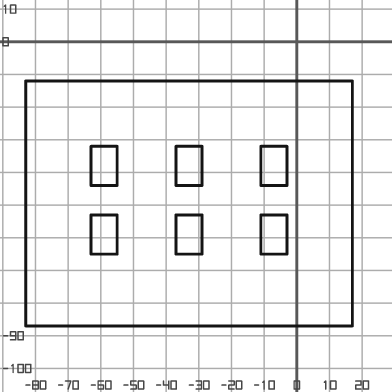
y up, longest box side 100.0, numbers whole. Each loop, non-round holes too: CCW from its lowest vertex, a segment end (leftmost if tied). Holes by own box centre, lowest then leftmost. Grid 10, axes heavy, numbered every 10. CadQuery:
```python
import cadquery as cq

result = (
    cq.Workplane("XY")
    .moveTo(-83.0, -87.0)
    .lineTo(17.0, -87.0)
    .lineTo(17.0, -12.0)
    .lineTo(-83.0, -12.0)
    .close()
    .moveTo(-63.0, -65.0)
    .lineTo(-55.0, -65.0)
    .lineTo(-55.0, -53.0)
    .lineTo(-63.0, -53.0)
    .close()
    .moveTo(-37.0, -65.0)
    .lineTo(-29.0, -65.0)
    .lineTo(-29.0, -53.0)
    .lineTo(-37.0, -53.0)
    .close()
    .moveTo(-11.0, -65.0)
    .lineTo(-3.0, -65.0)
    .lineTo(-3.0, -53.0)
    .lineTo(-11.0, -53.0)
    .close()
    .moveTo(-63.0, -44.0)
    .lineTo(-55.0, -44.0)
    .lineTo(-55.0, -32.0)
    .lineTo(-63.0, -32.0)
    .close()
    .moveTo(-37.0, -44.0)
    .lineTo(-29.0, -44.0)
    .lineTo(-29.0, -32.0)
    .lineTo(-37.0, -32.0)
    .close()
    .moveTo(-11.0, -44.0)
    .lineTo(-3.0, -44.0)
    .lineTo(-3.0, -32.0)
    .lineTo(-11.0, -32.0)
    .close()
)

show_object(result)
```